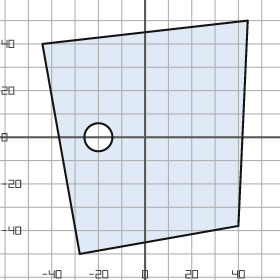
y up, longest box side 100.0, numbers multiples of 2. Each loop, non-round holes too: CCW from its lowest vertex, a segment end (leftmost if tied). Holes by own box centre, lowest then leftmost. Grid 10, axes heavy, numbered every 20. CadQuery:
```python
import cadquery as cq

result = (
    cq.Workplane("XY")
    .moveTo(-28.0, -50.0)
    .lineTo(40.0, -38.0)
    .lineTo(44.0, 50.0)
    .lineTo(-44.0, 40.0)
    .close()
    .moveTo(-20.0, 0.0)
    .circle(6.0)
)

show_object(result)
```